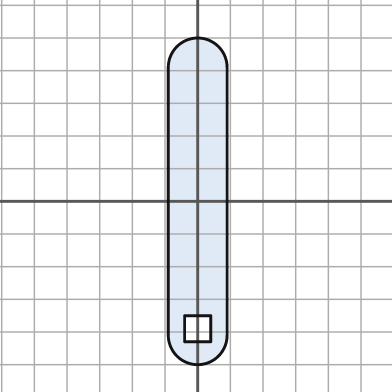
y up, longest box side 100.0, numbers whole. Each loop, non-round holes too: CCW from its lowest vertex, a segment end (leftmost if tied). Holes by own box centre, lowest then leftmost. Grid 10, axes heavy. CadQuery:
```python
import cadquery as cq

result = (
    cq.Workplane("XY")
    .moveTo(-9.0, -41.0)
    .threePointArc((0.0, -50.0), (9.0, -41.0))
    .lineTo(9.0, 41.0)
    .threePointArc((0.0, 50.0), (-9.0, 41.0))
    .close()
    .moveTo(-4.0, -43.0)
    .lineTo(4.0, -43.0)
    .lineTo(4.0, -35.0)
    .lineTo(-4.0, -35.0)
    .close()
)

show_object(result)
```